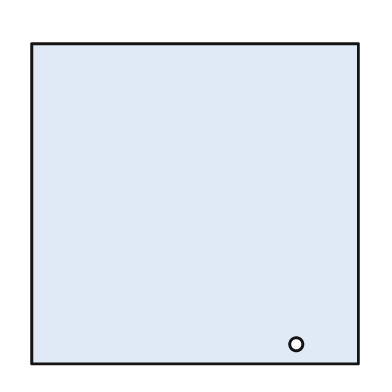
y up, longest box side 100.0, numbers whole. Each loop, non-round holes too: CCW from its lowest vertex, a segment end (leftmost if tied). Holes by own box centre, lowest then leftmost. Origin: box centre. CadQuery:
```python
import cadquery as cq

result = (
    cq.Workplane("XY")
    .moveTo(-50.0, -49.0)
    .lineTo(50.0, -49.0)
    .lineTo(50.0, 49.0)
    .lineTo(-50.0, 49.0)
    .close()
    .moveTo(31.0, -43.0)
    .circle(2.0)
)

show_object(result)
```